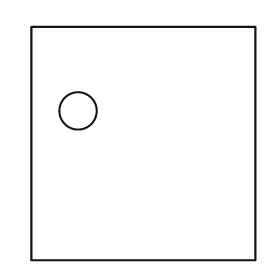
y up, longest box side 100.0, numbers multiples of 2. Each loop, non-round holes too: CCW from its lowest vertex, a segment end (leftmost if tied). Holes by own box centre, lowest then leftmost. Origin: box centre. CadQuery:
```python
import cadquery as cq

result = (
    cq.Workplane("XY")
    .moveTo(-48.0, -50.0)
    .lineTo(48.0, -50.0)
    .lineTo(48.0, 50.0)
    .lineTo(-48.0, 50.0)
    .close()
    .moveTo(-28.0, 14.0)
    .circle(8.0)
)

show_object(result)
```